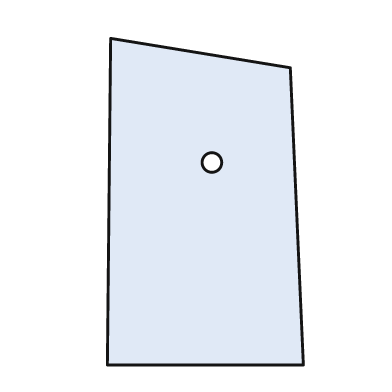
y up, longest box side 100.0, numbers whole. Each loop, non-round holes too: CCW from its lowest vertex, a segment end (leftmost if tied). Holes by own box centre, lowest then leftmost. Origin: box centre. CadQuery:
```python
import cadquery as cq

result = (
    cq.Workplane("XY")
    .moveTo(-30.0, -50.0)
    .lineTo(30.0, -50.0)
    .lineTo(26.0, 41.0)
    .lineTo(-29.0, 50.0)
    .close()
    .moveTo(2.0, 12.0)
    .circle(3.0)
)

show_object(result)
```